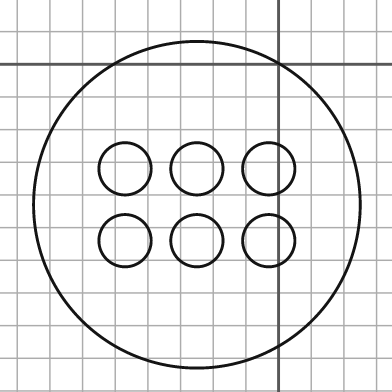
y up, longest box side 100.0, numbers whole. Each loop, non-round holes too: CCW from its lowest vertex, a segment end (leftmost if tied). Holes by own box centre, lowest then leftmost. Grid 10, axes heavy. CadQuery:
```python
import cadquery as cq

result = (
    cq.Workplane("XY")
    .moveTo(-25.0, -43.0)
    .circle(50.0)
    .moveTo(-47.0, -54.0)
    .circle(8.0)
    .moveTo(-25.0, -54.0)
    .circle(8.0)
    .moveTo(-3.0, -54.0)
    .circle(8.0)
    .moveTo(-47.0, -32.0)
    .circle(8.0)
    .moveTo(-25.0, -32.0)
    .circle(8.0)
    .moveTo(-3.0, -32.0)
    .circle(8.0)
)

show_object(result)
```